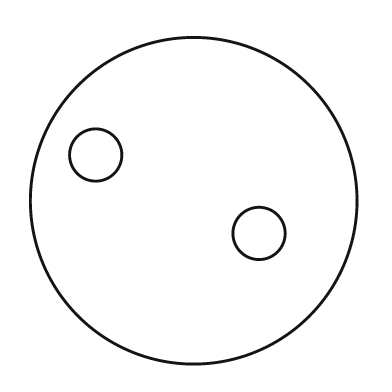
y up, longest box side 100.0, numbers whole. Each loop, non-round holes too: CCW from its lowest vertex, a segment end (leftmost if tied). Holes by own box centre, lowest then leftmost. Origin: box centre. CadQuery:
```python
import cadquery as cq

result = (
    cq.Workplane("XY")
    .moveTo(0.0, 0.0)
    .circle(50.0)
    .moveTo(20.0, -10.0)
    .circle(8.0)
    .moveTo(-30.0, 14.0)
    .circle(8.0)
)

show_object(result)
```